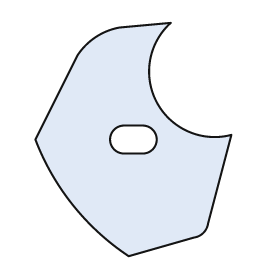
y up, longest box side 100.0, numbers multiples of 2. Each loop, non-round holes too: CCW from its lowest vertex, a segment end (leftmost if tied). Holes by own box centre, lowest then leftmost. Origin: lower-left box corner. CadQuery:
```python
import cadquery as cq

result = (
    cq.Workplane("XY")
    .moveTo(40.0, 0.0)
    .lineTo(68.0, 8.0)
    .threePointArc((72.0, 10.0), (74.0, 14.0))
    .lineTo(84.0, 52.0)
    .threePointArc((52.0, 66.0), (58.0, 100.0))
    .lineTo(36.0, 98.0)
    .threePointArc((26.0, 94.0), (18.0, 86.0))
    .lineTo(0.0, 50.0)
    .threePointArc((16.0, 22.0), (40.0, 0.0))
    .close()
    .moveTo(38.0, 44.0)
    .lineTo(46.0, 44.0)
    .threePointArc((52.0, 50.0), (46.0, 56.0))
    .lineTo(38.0, 56.0)
    .threePointArc((32.0, 50.0), (38.0, 44.0))
    .close()
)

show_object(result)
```